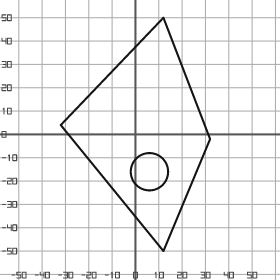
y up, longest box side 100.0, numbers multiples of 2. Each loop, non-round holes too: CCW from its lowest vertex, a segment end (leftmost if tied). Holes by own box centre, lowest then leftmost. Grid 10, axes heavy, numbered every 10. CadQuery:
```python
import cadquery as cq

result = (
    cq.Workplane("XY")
    .moveTo(12.0, -50.0)
    .lineTo(32.0, -2.0)
    .lineTo(12.0, 50.0)
    .lineTo(-32.0, 4.0)
    .close()
    .moveTo(6.0, -16.0)
    .circle(8.0)
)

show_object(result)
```